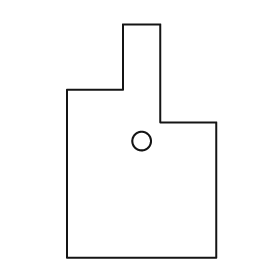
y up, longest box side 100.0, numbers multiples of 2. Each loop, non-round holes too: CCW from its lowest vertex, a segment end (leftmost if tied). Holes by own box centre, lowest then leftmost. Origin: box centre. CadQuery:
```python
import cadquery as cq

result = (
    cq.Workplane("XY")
    .moveTo(-32.0, -50.0)
    .lineTo(32.0, -50.0)
    .lineTo(32.0, 8.0)
    .lineTo(8.0, 8.0)
    .lineTo(8.0, 50.0)
    .lineTo(-8.0, 50.0)
    .lineTo(-8.0, 22.0)
    .lineTo(-32.0, 22.0)
    .close()
    .moveTo(0.0, 0.0)
    .circle(4.0)
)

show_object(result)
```